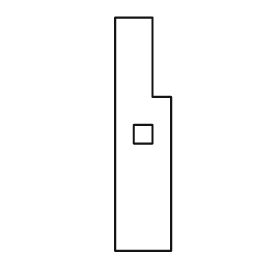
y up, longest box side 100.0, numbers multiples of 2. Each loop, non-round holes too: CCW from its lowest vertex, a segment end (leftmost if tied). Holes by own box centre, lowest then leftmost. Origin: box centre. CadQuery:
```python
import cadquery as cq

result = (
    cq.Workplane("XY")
    .moveTo(-12.0, -50.0)
    .lineTo(12.0, -50.0)
    .lineTo(12.0, 16.0)
    .lineTo(4.0, 16.0)
    .lineTo(4.0, 50.0)
    .lineTo(-12.0, 50.0)
    .close()
    .moveTo(-4.0, -4.0)
    .lineTo(4.0, -4.0)
    .lineTo(4.0, 4.0)
    .lineTo(-4.0, 4.0)
    .close()
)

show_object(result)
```